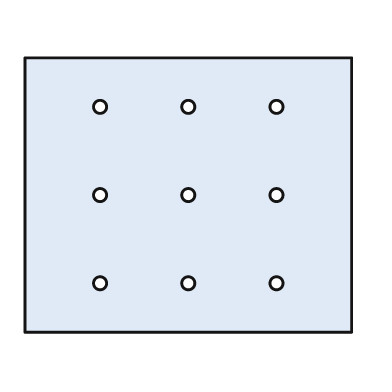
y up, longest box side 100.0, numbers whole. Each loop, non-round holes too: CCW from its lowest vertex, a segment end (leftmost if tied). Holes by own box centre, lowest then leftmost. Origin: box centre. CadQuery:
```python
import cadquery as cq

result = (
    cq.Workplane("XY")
    .moveTo(-50.0, -42.0)
    .lineTo(50.0, -42.0)
    .lineTo(50.0, 42.0)
    .lineTo(-50.0, 42.0)
    .close()
    .moveTo(-27.0, -27.0)
    .circle(2.0)
    .moveTo(0.0, -27.0)
    .circle(2.0)
    .moveTo(27.0, -27.0)
    .circle(2.0)
    .moveTo(-27.0, 0.0)
    .circle(2.0)
    .moveTo(0.0, 0.0)
    .circle(2.0)
    .moveTo(27.0, 0.0)
    .circle(2.0)
    .moveTo(-27.0, 27.0)
    .circle(2.0)
    .moveTo(0.0, 27.0)
    .circle(2.0)
    .moveTo(27.0, 27.0)
    .circle(2.0)
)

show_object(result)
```